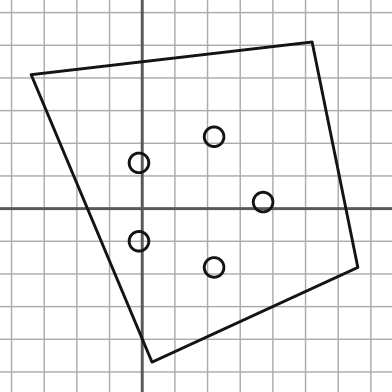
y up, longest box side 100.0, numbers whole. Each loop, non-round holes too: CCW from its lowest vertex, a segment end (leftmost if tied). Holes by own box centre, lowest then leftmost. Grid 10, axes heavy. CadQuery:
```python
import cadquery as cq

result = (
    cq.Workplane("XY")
    .moveTo(3.0, -47.0)
    .lineTo(66.0, -18.0)
    .lineTo(52.0, 51.0)
    .lineTo(-34.0, 41.0)
    .close()
    .moveTo(22.0, -18.0)
    .circle(3.0)
    .moveTo(-1.0, -10.0)
    .circle(3.0)
    .moveTo(37.0, 2.0)
    .circle(3.0)
    .moveTo(-1.0, 14.0)
    .circle(3.0)
    .moveTo(22.0, 22.0)
    .circle(3.0)
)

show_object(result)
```